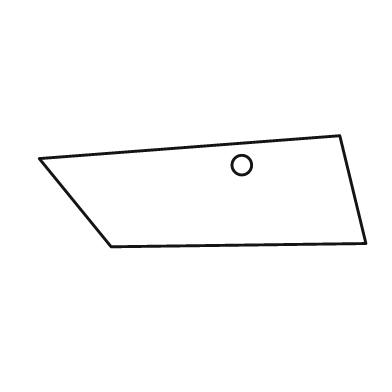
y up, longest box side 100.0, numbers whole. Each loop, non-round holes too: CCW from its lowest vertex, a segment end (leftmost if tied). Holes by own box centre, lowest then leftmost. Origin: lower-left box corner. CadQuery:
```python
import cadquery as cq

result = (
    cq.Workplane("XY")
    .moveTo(22.0, 0.0)
    .lineTo(100.0, 1.0)
    .lineTo(92.0, 34.0)
    .lineTo(0.0, 27.0)
    .close()
    .moveTo(62.0, 25.0)
    .circle(3.0)
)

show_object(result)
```